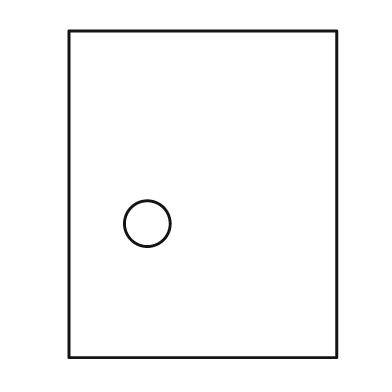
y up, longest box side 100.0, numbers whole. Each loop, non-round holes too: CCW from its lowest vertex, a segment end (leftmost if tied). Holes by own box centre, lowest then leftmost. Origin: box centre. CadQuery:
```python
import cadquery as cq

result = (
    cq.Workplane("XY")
    .moveTo(-41.0, -50.0)
    .lineTo(41.0, -50.0)
    .lineTo(41.0, 50.0)
    .lineTo(-41.0, 50.0)
    .close()
    .moveTo(-17.0, -9.0)
    .circle(7.0)
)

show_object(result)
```